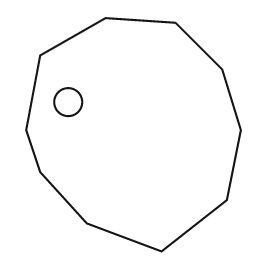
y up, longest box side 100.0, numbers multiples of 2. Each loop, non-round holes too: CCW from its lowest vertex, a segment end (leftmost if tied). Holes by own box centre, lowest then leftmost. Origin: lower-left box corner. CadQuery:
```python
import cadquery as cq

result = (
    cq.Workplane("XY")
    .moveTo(58.0, 0.0)
    .lineTo(86.0, 22.0)
    .lineTo(92.0, 52.0)
    .lineTo(84.0, 78.0)
    .lineTo(64.0, 98.0)
    .lineTo(34.0, 100.0)
    .lineTo(6.0, 84.0)
    .lineTo(0.0, 52.0)
    .lineTo(6.0, 34.0)
    .lineTo(26.0, 12.0)
    .close()
    .moveTo(18.0, 64.0)
    .circle(6.0)
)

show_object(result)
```